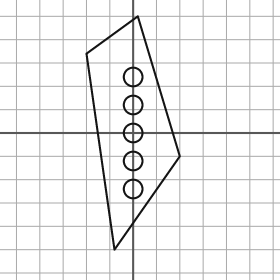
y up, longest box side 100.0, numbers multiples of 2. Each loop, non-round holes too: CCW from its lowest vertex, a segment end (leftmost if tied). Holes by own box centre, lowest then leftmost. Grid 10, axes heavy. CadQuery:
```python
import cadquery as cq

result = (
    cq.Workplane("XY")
    .moveTo(-8.0, -50.0)
    .lineTo(20.0, -10.0)
    .lineTo(2.0, 50.0)
    .lineTo(-20.0, 34.0)
    .close()
    .moveTo(0.0, -24.0)
    .circle(4.0)
    .moveTo(0.0, -12.0)
    .circle(4.0)
    .moveTo(0.0, 0.0)
    .circle(4.0)
    .moveTo(0.0, 12.0)
    .circle(4.0)
    .moveTo(0.0, 24.0)
    .circle(4.0)
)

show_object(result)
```